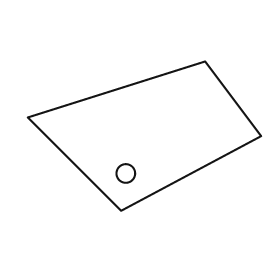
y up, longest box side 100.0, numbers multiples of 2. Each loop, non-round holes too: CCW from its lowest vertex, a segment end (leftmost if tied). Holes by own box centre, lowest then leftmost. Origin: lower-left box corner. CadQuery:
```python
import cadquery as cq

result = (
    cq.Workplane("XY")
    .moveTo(40.0, 0.0)
    .lineTo(100.0, 32.0)
    .lineTo(76.0, 64.0)
    .lineTo(0.0, 40.0)
    .close()
    .moveTo(42.0, 16.0)
    .circle(4.0)
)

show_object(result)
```